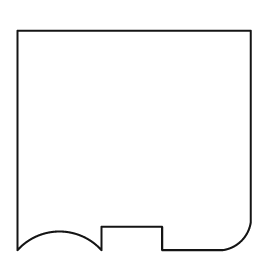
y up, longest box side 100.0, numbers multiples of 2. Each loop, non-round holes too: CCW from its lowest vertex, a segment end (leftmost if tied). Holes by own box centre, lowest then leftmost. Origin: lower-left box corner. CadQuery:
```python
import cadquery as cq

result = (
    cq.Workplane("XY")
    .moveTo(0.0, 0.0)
    .threePointArc((18.0, 8.0), (36.0, 0.0))
    .lineTo(36.0, 10.0)
    .lineTo(62.0, 10.0)
    .lineTo(62.0, 0.0)
    .lineTo(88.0, 0.0)
    .threePointArc((96.0, 4.0), (100.0, 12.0))
    .lineTo(100.0, 94.0)
    .lineTo(0.0, 94.0)
    .close()
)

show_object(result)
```